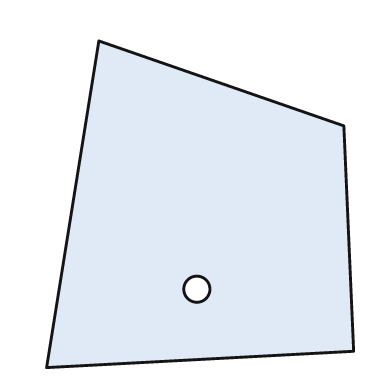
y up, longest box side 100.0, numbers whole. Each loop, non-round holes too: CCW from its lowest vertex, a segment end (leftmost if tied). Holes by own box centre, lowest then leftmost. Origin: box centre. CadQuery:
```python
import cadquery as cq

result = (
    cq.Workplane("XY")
    .moveTo(-47.0, -50.0)
    .lineTo(47.0, -45.0)
    .lineTo(44.0, 24.0)
    .lineTo(-31.0, 50.0)
    .close()
    .moveTo(-1.0, -26.0)
    .circle(4.0)
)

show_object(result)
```